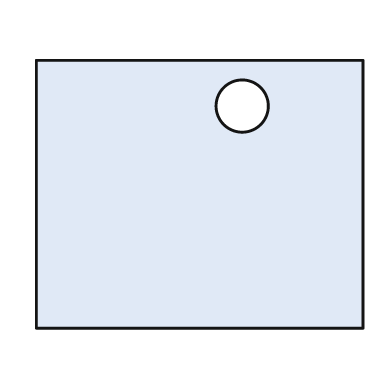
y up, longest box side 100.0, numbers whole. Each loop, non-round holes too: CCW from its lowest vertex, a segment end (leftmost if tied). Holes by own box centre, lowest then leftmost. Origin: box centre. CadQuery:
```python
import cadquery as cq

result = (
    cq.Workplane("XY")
    .moveTo(-50.0, -41.0)
    .lineTo(50.0, -41.0)
    .lineTo(50.0, 41.0)
    .lineTo(-50.0, 41.0)
    .close()
    .moveTo(13.0, 27.0)
    .circle(8.0)
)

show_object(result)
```